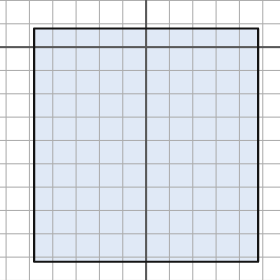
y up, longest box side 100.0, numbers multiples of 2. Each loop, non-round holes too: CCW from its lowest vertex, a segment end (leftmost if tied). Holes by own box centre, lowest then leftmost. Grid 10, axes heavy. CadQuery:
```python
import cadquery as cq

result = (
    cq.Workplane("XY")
    .moveTo(-48.0, -92.0)
    .lineTo(48.0, -92.0)
    .lineTo(48.0, 8.0)
    .lineTo(-48.0, 8.0)
    .close()
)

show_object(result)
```